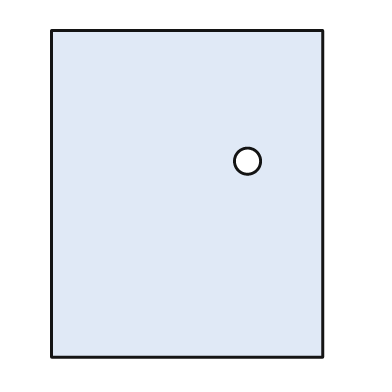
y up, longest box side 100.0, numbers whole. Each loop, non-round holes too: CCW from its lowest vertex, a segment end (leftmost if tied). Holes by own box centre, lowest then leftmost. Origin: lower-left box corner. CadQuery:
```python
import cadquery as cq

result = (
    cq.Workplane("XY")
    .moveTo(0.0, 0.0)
    .lineTo(83.0, 0.0)
    .lineTo(83.0, 100.0)
    .lineTo(0.0, 100.0)
    .close()
    .moveTo(60.0, 60.0)
    .circle(4.0)
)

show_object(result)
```